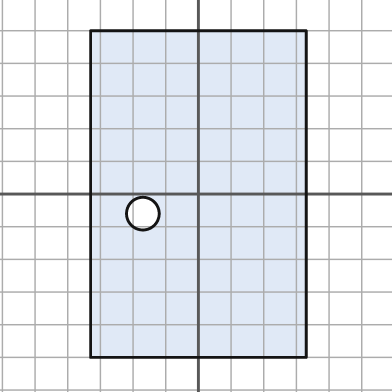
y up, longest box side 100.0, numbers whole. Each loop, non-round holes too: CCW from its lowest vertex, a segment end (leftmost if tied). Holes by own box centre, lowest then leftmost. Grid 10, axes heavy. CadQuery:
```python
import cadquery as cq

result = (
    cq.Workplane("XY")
    .moveTo(-33.0, -50.0)
    .lineTo(33.0, -50.0)
    .lineTo(33.0, 50.0)
    .lineTo(-33.0, 50.0)
    .close()
    .moveTo(-17.0, -6.0)
    .circle(5.0)
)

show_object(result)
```